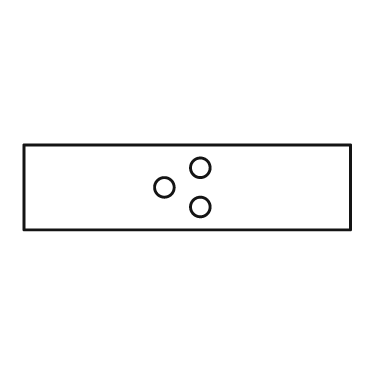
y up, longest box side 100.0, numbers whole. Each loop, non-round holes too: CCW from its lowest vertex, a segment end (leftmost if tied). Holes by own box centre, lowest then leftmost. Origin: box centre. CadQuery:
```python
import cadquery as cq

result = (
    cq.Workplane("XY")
    .moveTo(-50.0, -13.0)
    .lineTo(50.0, -13.0)
    .lineTo(50.0, 13.0)
    .lineTo(-50.0, 13.0)
    .close()
    .moveTo(4.0, -6.0)
    .circle(3.0)
    .moveTo(-7.0, 0.0)
    .circle(3.0)
    .moveTo(4.0, 6.0)
    .circle(3.0)
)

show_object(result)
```